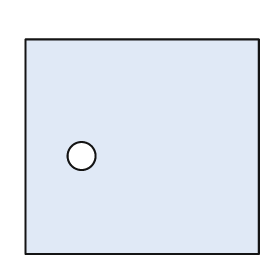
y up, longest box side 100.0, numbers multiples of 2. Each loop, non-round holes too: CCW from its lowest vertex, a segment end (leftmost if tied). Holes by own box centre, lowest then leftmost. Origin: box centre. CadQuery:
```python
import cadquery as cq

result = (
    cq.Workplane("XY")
    .moveTo(-50.0, -46.0)
    .lineTo(50.0, -46.0)
    .lineTo(50.0, 46.0)
    .lineTo(-50.0, 46.0)
    .close()
    .moveTo(-26.0, -4.0)
    .circle(6.0)
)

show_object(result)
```